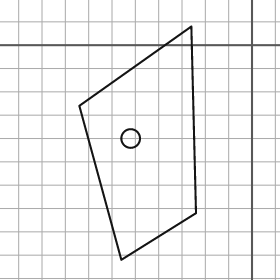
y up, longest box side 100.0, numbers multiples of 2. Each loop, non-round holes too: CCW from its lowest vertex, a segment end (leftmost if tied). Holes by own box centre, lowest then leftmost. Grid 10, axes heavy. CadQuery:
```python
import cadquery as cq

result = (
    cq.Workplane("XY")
    .moveTo(-56.0, -92.0)
    .lineTo(-24.0, -72.0)
    .lineTo(-26.0, 8.0)
    .lineTo(-74.0, -26.0)
    .close()
    .moveTo(-52.0, -40.0)
    .circle(4.0)
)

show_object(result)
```